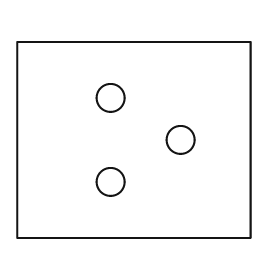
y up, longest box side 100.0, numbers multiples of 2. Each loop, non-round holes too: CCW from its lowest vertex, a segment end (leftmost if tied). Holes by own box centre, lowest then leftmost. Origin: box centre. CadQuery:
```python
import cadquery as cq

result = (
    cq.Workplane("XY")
    .moveTo(-50.0, -42.0)
    .lineTo(50.0, -42.0)
    .lineTo(50.0, 42.0)
    .lineTo(-50.0, 42.0)
    .close()
    .moveTo(-10.0, -18.0)
    .circle(6.0)
    .moveTo(20.0, 0.0)
    .circle(6.0)
    .moveTo(-10.0, 18.0)
    .circle(6.0)
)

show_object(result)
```